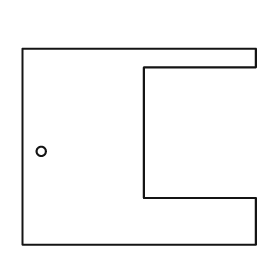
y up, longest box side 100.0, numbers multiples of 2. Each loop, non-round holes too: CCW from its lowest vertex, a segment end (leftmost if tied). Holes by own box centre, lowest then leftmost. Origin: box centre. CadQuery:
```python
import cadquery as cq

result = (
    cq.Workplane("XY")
    .moveTo(-50.0, -42.0)
    .lineTo(50.0, -42.0)
    .lineTo(50.0, -22.0)
    .lineTo(2.0, -22.0)
    .lineTo(2.0, 34.0)
    .lineTo(50.0, 34.0)
    .lineTo(50.0, 42.0)
    .lineTo(-50.0, 42.0)
    .close()
    .moveTo(-42.0, -2.0)
    .circle(2.0)
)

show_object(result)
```